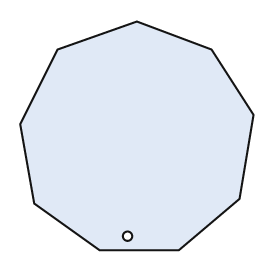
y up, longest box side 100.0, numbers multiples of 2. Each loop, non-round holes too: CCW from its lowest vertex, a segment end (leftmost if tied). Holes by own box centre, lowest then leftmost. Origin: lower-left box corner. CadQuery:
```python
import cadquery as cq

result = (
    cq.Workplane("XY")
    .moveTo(34.0, 0.0)
    .lineTo(68.0, 0.0)
    .lineTo(94.0, 22.0)
    .lineTo(100.0, 58.0)
    .lineTo(82.0, 86.0)
    .lineTo(50.0, 98.0)
    .lineTo(16.0, 86.0)
    .lineTo(0.0, 54.0)
    .lineTo(6.0, 20.0)
    .close()
    .moveTo(46.0, 6.0)
    .circle(2.0)
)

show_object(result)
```